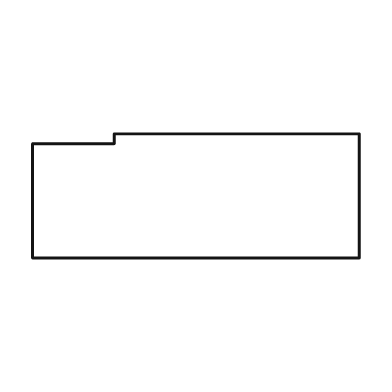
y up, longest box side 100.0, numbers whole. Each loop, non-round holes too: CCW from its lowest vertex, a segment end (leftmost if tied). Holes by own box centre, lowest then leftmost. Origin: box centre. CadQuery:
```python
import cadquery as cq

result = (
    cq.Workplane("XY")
    .moveTo(-50.0, -19.0)
    .lineTo(50.0, -19.0)
    .lineTo(50.0, 19.0)
    .lineTo(-25.0, 19.0)
    .lineTo(-25.0, 16.0)
    .lineTo(-50.0, 16.0)
    .close()
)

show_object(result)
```